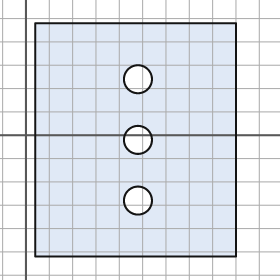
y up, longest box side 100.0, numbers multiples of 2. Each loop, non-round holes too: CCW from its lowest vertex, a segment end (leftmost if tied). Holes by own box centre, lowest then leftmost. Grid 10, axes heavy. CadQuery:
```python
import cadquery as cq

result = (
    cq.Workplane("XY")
    .moveTo(4.0, -52.0)
    .lineTo(90.0, -52.0)
    .lineTo(90.0, 48.0)
    .lineTo(4.0, 48.0)
    .close()
    .moveTo(48.0, -28.0)
    .circle(6.0)
    .moveTo(48.0, -2.0)
    .circle(6.0)
    .moveTo(48.0, 24.0)
    .circle(6.0)
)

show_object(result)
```